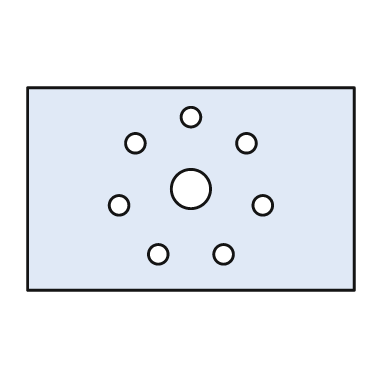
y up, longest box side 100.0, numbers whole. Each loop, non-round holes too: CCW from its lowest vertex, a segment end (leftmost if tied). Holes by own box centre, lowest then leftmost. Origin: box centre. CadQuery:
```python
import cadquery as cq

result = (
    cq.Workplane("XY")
    .moveTo(-50.0, -31.0)
    .lineTo(50.0, -31.0)
    .lineTo(50.0, 31.0)
    .lineTo(-50.0, 31.0)
    .close()
    .moveTo(-10.0, -20.0)
    .circle(3.0)
    .moveTo(10.0, -20.0)
    .circle(3.0)
    .moveTo(-22.0, -5.0)
    .circle(3.0)
    .moveTo(22.0, -5.0)
    .circle(3.0)
    .moveTo(0.0, 0.0)
    .circle(6.0)
    .moveTo(-17.0, 14.0)
    .circle(3.0)
    .moveTo(17.0, 14.0)
    .circle(3.0)
    .moveTo(0.0, 22.0)
    .circle(3.0)
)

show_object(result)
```